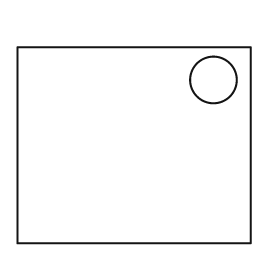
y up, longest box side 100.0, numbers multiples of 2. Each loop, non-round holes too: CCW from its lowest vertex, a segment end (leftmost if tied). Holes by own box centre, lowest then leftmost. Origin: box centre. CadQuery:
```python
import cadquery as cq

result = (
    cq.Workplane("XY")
    .moveTo(-50.0, -42.0)
    .lineTo(50.0, -42.0)
    .lineTo(50.0, 42.0)
    .lineTo(-50.0, 42.0)
    .close()
    .moveTo(34.0, 28.0)
    .circle(10.0)
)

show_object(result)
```